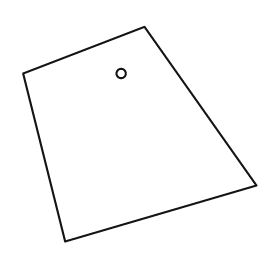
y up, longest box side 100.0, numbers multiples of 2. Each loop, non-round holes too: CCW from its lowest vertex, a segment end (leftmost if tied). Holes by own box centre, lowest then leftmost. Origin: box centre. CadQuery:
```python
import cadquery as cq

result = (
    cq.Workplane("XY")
    .moveTo(-32.0, -46.0)
    .lineTo(50.0, -22.0)
    .lineTo(2.0, 46.0)
    .lineTo(-50.0, 26.0)
    .close()
    .moveTo(-8.0, 26.0)
    .circle(2.0)
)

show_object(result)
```